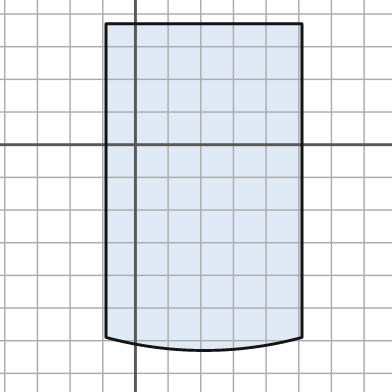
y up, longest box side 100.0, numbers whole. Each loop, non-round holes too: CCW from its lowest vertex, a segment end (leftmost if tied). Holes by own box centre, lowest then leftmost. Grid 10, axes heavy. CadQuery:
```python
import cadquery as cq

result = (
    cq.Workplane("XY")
    .moveTo(-9.0, -59.0)
    .threePointArc((21.0, -63.0), (51.0, -59.0))
    .lineTo(51.0, 37.0)
    .lineTo(-9.0, 37.0)
    .close()
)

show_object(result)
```